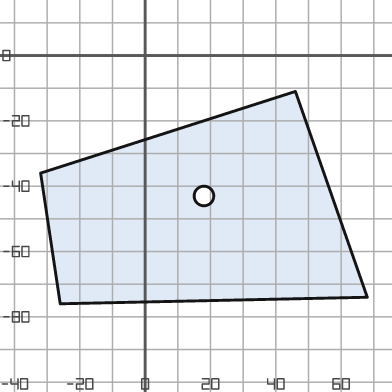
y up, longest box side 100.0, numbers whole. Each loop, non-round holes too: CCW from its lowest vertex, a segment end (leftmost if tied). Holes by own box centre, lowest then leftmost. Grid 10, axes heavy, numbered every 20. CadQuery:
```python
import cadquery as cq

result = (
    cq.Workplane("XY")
    .moveTo(-26.0, -76.0)
    .lineTo(68.0, -74.0)
    .lineTo(46.0, -11.0)
    .lineTo(-32.0, -36.0)
    .close()
    .moveTo(18.0, -43.0)
    .circle(3.0)
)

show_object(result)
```